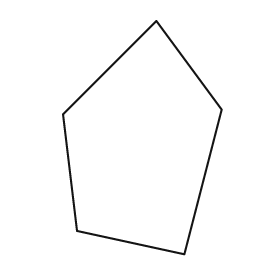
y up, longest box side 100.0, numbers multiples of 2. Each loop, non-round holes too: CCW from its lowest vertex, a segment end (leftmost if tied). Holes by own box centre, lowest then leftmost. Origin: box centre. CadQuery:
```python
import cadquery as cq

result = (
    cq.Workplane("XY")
    .moveTo(18.0, -50.0)
    .lineTo(34.0, 12.0)
    .lineTo(6.0, 50.0)
    .lineTo(-34.0, 10.0)
    .lineTo(-28.0, -40.0)
    .close()
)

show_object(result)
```